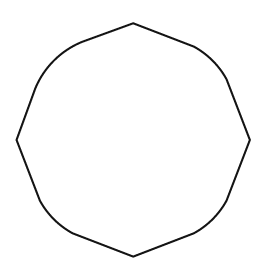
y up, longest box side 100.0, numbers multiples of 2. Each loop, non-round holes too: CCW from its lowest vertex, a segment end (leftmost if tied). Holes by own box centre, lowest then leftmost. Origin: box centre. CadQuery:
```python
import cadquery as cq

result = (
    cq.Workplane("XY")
    .moveTo(0.0, -50.0)
    .lineTo(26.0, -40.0)
    .threePointArc((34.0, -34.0), (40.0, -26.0))
    .lineTo(50.0, 0.0)
    .lineTo(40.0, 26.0)
    .threePointArc((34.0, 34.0), (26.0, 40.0))
    .lineTo(0.0, 50.0)
    .lineTo(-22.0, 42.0)
    .threePointArc((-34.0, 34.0), (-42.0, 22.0))
    .lineTo(-50.0, 0.0)
    .lineTo(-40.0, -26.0)
    .threePointArc((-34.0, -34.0), (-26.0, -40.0))
    .close()
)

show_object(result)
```